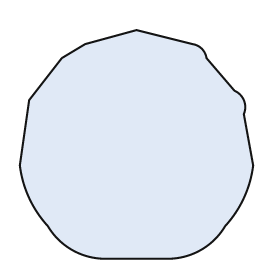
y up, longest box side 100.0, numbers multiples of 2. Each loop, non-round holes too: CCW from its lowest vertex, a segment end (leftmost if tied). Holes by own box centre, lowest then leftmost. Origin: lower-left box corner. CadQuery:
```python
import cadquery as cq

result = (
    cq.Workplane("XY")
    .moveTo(36.0, 0.0)
    .lineTo(64.0, 0.0)
    .threePointArc((78.0, 4.0), (88.0, 14.0))
    .threePointArc((96.0, 26.0), (100.0, 40.0))
    .lineTo(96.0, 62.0)
    .threePointArc((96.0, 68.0), (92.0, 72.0))
    .lineTo(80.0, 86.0)
    .threePointArc((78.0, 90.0), (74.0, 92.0))
    .lineTo(50.0, 98.0)
    .lineTo(28.0, 92.0)
    .lineTo(18.0, 86.0)
    .lineTo(4.0, 68.0)
    .lineTo(0.0, 40.0)
    .threePointArc((4.0, 26.0), (12.0, 14.0))
    .threePointArc((22.0, 4.0), (36.0, 0.0))
    .close()
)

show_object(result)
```